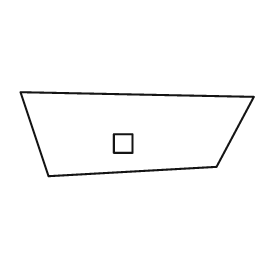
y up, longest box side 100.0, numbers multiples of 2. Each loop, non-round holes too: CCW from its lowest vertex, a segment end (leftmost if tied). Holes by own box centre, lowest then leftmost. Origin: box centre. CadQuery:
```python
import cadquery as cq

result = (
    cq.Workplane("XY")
    .moveTo(-38.0, -18.0)
    .lineTo(34.0, -14.0)
    .lineTo(50.0, 16.0)
    .lineTo(-50.0, 18.0)
    .close()
    .moveTo(-10.0, -8.0)
    .lineTo(-2.0, -8.0)
    .lineTo(-2.0, 0.0)
    .lineTo(-10.0, 0.0)
    .close()
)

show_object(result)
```